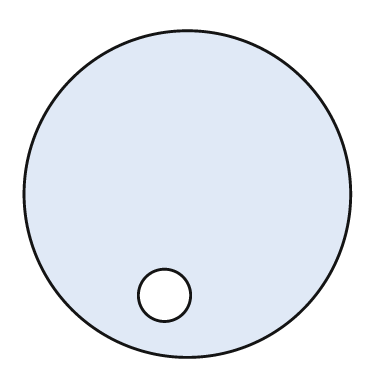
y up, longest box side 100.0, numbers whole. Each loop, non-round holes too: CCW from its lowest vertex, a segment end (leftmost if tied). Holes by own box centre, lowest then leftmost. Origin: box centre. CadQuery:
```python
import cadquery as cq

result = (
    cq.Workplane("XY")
    .moveTo(0.0, 0.0)
    .circle(50.0)
    .moveTo(-7.0, -31.0)
    .circle(8.0)
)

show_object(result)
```